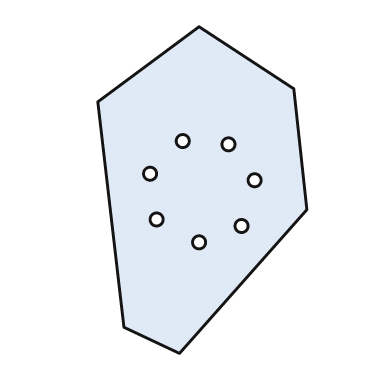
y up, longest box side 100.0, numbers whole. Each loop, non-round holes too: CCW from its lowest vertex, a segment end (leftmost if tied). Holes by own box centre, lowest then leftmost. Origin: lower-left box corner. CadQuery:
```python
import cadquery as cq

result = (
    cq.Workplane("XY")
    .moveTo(25.0, 0.0)
    .lineTo(64.0, 44.0)
    .lineTo(60.0, 81.0)
    .lineTo(31.0, 100.0)
    .lineTo(0.0, 77.0)
    .lineTo(8.0, 8.0)
    .close()
    .moveTo(31.0, 34.0)
    .circle(2.0)
    .moveTo(44.0, 39.0)
    .circle(2.0)
    .moveTo(18.0, 41.0)
    .circle(2.0)
    .moveTo(48.0, 53.0)
    .circle(2.0)
    .moveTo(16.0, 55.0)
    .circle(2.0)
    .moveTo(40.0, 64.0)
    .circle(2.0)
    .moveTo(26.0, 65.0)
    .circle(2.0)
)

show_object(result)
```